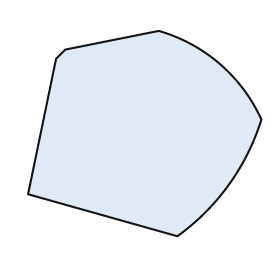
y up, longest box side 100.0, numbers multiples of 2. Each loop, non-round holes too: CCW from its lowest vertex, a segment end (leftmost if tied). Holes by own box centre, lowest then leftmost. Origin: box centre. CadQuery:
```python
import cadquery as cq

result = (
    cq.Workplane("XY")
    .moveTo(14.0, -44.0)
    .threePointArc((36.0, -22.0), (50.0, 6.0))
    .threePointArc((32.0, 30.0), (6.0, 44.0))
    .lineTo(-34.0, 36.0)
    .lineTo(-38.0, 32.0)
    .lineTo(-50.0, -26.0)
    .close()
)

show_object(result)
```